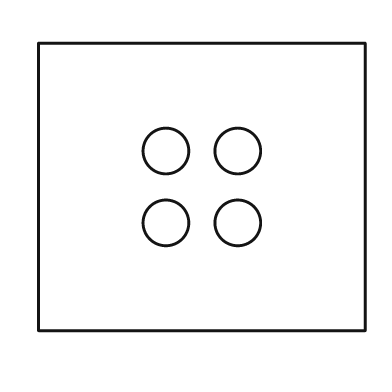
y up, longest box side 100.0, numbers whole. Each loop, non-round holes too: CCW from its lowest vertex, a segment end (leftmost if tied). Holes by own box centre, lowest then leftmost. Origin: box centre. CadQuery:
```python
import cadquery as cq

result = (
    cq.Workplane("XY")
    .moveTo(-50.0, -44.0)
    .lineTo(50.0, -44.0)
    .lineTo(50.0, 44.0)
    .lineTo(-50.0, 44.0)
    .close()
    .moveTo(-11.0, -11.0)
    .circle(7.0)
    .moveTo(11.0, -11.0)
    .circle(7.0)
    .moveTo(-11.0, 11.0)
    .circle(7.0)
    .moveTo(11.0, 11.0)
    .circle(7.0)
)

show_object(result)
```